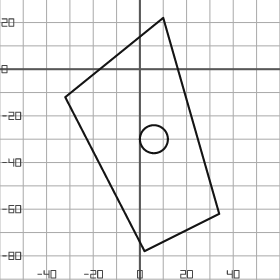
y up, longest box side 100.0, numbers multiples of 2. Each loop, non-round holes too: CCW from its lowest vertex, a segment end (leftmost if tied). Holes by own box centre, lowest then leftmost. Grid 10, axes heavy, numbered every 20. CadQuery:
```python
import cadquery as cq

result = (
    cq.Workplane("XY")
    .moveTo(2.0, -78.0)
    .lineTo(34.0, -62.0)
    .lineTo(10.0, 22.0)
    .lineTo(-32.0, -12.0)
    .close()
    .moveTo(6.0, -30.0)
    .circle(6.0)
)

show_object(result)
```